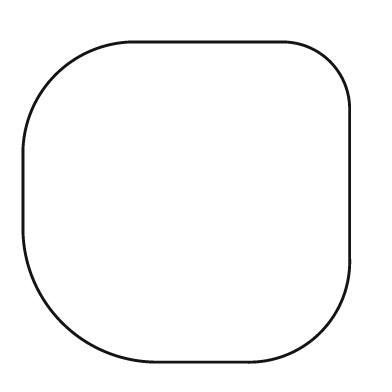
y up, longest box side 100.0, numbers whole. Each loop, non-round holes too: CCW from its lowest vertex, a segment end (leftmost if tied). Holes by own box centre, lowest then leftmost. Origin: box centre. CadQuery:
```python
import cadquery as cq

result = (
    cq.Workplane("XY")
    .moveTo(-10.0, -49.0)
    .lineTo(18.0, -49.0)
    .threePointArc((41.0, -40.0), (50.0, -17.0))
    .lineTo(50.0, 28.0)
    .threePointArc((44.0, 43.0), (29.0, 49.0))
    .lineTo(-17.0, 49.0)
    .threePointArc((-40.0, 39.0), (-50.0, 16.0))
    .lineTo(-50.0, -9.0)
    .threePointArc((-38.0, -37.0), (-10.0, -49.0))
    .close()
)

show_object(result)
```